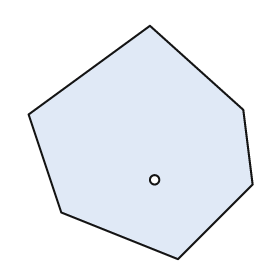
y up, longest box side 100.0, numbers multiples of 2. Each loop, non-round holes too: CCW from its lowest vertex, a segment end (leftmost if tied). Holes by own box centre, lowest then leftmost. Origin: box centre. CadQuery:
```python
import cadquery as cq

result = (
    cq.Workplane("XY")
    .moveTo(16.0, -50.0)
    .lineTo(48.0, -18.0)
    .lineTo(44.0, 14.0)
    .lineTo(4.0, 50.0)
    .lineTo(-48.0, 12.0)
    .lineTo(-34.0, -30.0)
    .close()
    .moveTo(6.0, -16.0)
    .circle(2.0)
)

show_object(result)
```